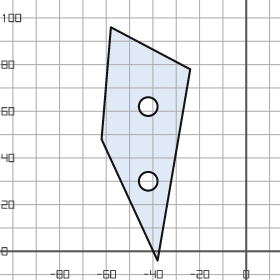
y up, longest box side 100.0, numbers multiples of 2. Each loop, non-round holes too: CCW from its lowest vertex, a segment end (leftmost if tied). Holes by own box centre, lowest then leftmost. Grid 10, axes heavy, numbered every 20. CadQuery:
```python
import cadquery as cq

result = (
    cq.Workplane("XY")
    .moveTo(-38.0, -4.0)
    .lineTo(-24.0, 78.0)
    .lineTo(-58.0, 96.0)
    .lineTo(-62.0, 48.0)
    .close()
    .moveTo(-42.0, 30.0)
    .circle(4.0)
    .moveTo(-42.0, 62.0)
    .circle(4.0)
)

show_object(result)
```